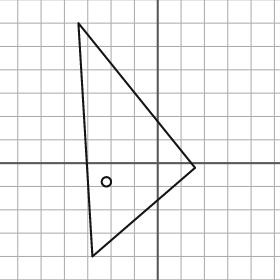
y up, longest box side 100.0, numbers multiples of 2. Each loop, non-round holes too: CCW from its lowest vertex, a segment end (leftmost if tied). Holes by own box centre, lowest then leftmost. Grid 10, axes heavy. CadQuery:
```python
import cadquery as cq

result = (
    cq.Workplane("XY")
    .moveTo(-28.0, -40.0)
    .lineTo(16.0, -2.0)
    .lineTo(-34.0, 60.0)
    .close()
    .moveTo(-22.0, -8.0)
    .circle(2.0)
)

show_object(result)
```